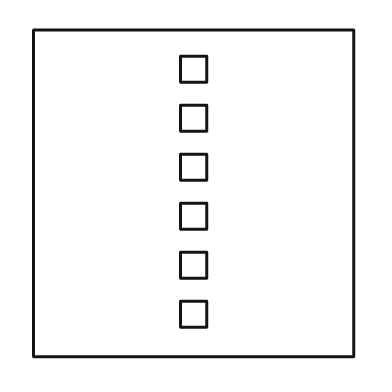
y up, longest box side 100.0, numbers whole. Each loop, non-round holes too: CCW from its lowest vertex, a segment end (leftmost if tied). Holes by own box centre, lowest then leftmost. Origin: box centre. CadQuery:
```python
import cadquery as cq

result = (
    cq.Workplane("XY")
    .moveTo(-49.0, -50.0)
    .lineTo(49.0, -50.0)
    .lineTo(49.0, 50.0)
    .lineTo(-49.0, 50.0)
    .close()
    .moveTo(-4.0, -41.0)
    .lineTo(4.0, -41.0)
    .lineTo(4.0, -33.0)
    .lineTo(-4.0, -33.0)
    .close()
    .moveTo(-4.0, -26.0)
    .lineTo(4.0, -26.0)
    .lineTo(4.0, -18.0)
    .lineTo(-4.0, -18.0)
    .close()
    .moveTo(-4.0, -11.0)
    .lineTo(4.0, -11.0)
    .lineTo(4.0, -3.0)
    .lineTo(-4.0, -3.0)
    .close()
    .moveTo(-4.0, 4.0)
    .lineTo(4.0, 4.0)
    .lineTo(4.0, 12.0)
    .lineTo(-4.0, 12.0)
    .close()
    .moveTo(-4.0, 19.0)
    .lineTo(4.0, 19.0)
    .lineTo(4.0, 27.0)
    .lineTo(-4.0, 27.0)
    .close()
    .moveTo(-4.0, 34.0)
    .lineTo(4.0, 34.0)
    .lineTo(4.0, 42.0)
    .lineTo(-4.0, 42.0)
    .close()
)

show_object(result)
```